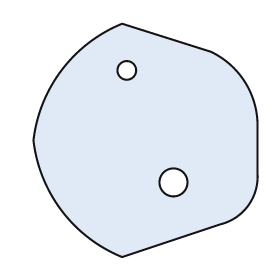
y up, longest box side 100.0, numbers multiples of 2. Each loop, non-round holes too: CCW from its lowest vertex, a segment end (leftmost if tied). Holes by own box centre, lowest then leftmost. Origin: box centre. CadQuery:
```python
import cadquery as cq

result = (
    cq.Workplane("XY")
    .moveTo(-10.0, -50.0)
    .lineTo(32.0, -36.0)
    .threePointArc((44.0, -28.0), (48.0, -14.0))
    .lineTo(48.0, 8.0)
    .threePointArc((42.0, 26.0), (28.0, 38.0))
    .lineTo(-10.0, 50.0)
    .threePointArc((-36.0, 30.0), (-48.0, 0.0))
    .threePointArc((-36.0, -30.0), (-10.0, -50.0))
    .close()
    .moveTo(12.0, -18.0)
    .circle(6.0)
    .moveTo(-8.0, 30.0)
    .circle(4.0)
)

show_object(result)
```